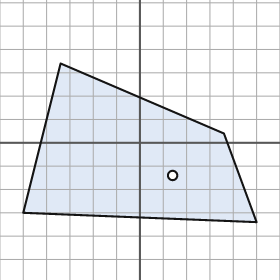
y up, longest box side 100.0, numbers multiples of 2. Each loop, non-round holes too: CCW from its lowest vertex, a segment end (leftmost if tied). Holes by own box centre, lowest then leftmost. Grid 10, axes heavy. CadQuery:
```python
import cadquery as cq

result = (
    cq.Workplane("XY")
    .moveTo(50.0, -34.0)
    .lineTo(36.0, 4.0)
    .lineTo(-34.0, 34.0)
    .lineTo(-50.0, -30.0)
    .close()
    .moveTo(14.0, -14.0)
    .circle(2.0)
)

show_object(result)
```